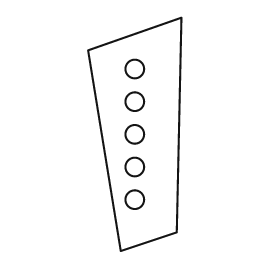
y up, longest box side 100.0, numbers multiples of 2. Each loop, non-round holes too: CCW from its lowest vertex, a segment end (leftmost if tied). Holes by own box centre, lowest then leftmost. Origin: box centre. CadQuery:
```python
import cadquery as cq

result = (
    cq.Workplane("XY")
    .moveTo(-6.0, -50.0)
    .lineTo(18.0, -42.0)
    .lineTo(20.0, 50.0)
    .lineTo(-20.0, 36.0)
    .close()
    .moveTo(0.0, -28.0)
    .circle(4.0)
    .moveTo(0.0, -14.0)
    .circle(4.0)
    .moveTo(0.0, 0.0)
    .circle(4.0)
    .moveTo(0.0, 14.0)
    .circle(4.0)
    .moveTo(0.0, 28.0)
    .circle(4.0)
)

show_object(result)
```